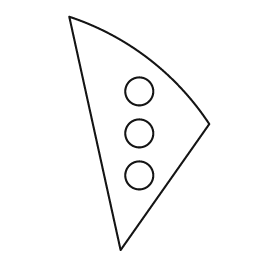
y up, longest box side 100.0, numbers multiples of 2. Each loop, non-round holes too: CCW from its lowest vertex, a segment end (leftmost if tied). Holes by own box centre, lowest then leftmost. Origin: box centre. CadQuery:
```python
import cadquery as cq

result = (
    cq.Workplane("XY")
    .moveTo(-8.0, -50.0)
    .lineTo(30.0, 4.0)
    .threePointArc((4.0, 32.0), (-30.0, 50.0))
    .close()
    .moveTo(0.0, -18.0)
    .circle(6.0)
    .moveTo(0.0, 0.0)
    .circle(6.0)
    .moveTo(0.0, 18.0)
    .circle(6.0)
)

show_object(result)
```